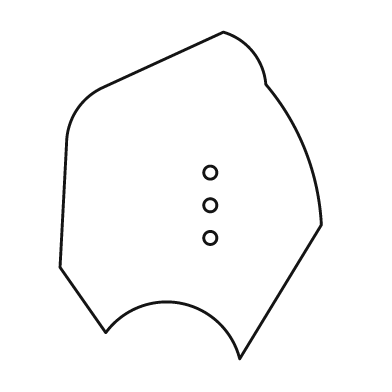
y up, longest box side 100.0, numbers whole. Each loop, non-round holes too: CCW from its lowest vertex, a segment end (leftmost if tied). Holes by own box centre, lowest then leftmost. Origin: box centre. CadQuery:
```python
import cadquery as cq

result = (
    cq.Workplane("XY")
    .moveTo(15.0, -50.0)
    .lineTo(40.0, -9.0)
    .threePointArc((35.0, 14.0), (23.0, 34.0))
    .threePointArc((19.0, 44.0), (10.0, 50.0))
    .lineTo(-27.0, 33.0)
    .threePointArc((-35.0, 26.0), (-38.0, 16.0))
    .lineTo(-40.0, -22.0)
    .lineTo(-26.0, -42.0)
    .threePointArc((-3.0, -33.0), (15.0, -50.0))
    .close()
    .moveTo(6.0, -13.0)
    .circle(2.0)
    .moveTo(6.0, -3.0)
    .circle(2.0)
    .moveTo(6.0, 7.0)
    .circle(2.0)
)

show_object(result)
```